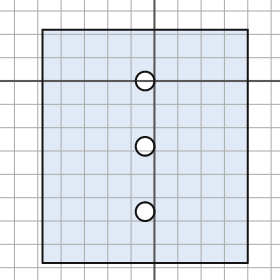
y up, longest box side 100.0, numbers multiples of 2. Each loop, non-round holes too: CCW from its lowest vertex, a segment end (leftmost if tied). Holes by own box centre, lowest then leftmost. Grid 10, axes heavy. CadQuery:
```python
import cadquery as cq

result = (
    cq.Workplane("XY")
    .moveTo(-48.0, -78.0)
    .lineTo(40.0, -78.0)
    .lineTo(40.0, 22.0)
    .lineTo(-48.0, 22.0)
    .close()
    .moveTo(-4.0, -56.0)
    .circle(4.0)
    .moveTo(-4.0, -28.0)
    .circle(4.0)
    .moveTo(-4.0, 0.0)
    .circle(4.0)
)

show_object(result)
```